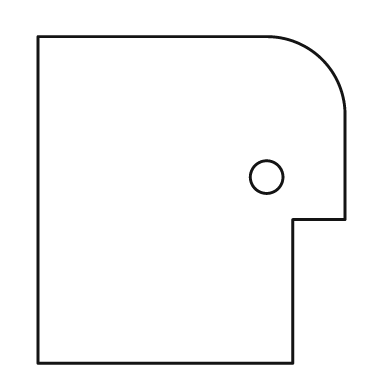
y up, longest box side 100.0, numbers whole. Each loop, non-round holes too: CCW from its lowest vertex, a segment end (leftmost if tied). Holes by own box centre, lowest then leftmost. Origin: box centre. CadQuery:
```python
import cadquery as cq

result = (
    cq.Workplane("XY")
    .moveTo(-47.0, -50.0)
    .lineTo(31.0, -50.0)
    .lineTo(31.0, -6.0)
    .lineTo(47.0, -6.0)
    .lineTo(47.0, 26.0)
    .threePointArc((40.0, 43.0), (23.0, 50.0))
    .lineTo(-47.0, 50.0)
    .close()
    .moveTo(23.0, 7.0)
    .circle(5.0)
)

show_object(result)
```